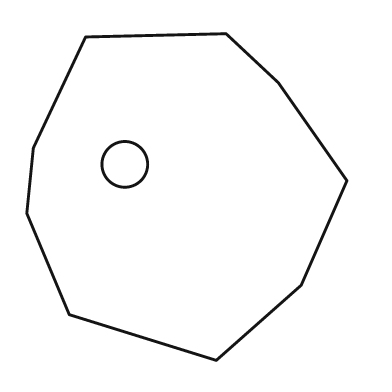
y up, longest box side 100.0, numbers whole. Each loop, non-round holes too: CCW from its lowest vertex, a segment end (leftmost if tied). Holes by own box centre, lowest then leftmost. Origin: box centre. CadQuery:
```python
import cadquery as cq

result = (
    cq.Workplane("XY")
    .moveTo(9.0, -50.0)
    .lineTo(35.0, -27.0)
    .lineTo(49.0, 5.0)
    .lineTo(28.0, 35.0)
    .lineTo(12.0, 50.0)
    .lineTo(-31.0, 49.0)
    .lineTo(-47.0, 15.0)
    .lineTo(-49.0, -5.0)
    .lineTo(-36.0, -36.0)
    .close()
    .moveTo(-19.0, 10.0)
    .circle(7.0)
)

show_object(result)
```